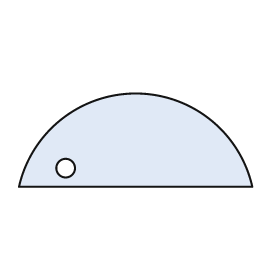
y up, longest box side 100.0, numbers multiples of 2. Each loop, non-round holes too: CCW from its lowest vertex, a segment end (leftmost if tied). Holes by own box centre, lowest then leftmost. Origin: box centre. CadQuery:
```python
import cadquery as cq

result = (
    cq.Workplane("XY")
    .moveTo(-50.0, -20.0)
    .lineTo(50.0, -20.0)
    .threePointArc((0.0, 20.0), (-50.0, -20.0))
    .close()
    .moveTo(-30.0, -12.0)
    .circle(4.0)
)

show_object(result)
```